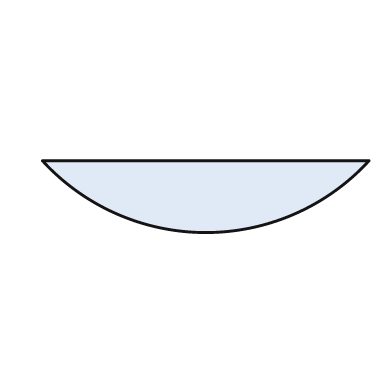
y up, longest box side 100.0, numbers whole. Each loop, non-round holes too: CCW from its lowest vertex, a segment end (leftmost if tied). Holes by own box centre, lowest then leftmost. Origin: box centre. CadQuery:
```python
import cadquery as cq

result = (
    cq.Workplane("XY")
    .moveTo(-50.0, 11.0)
    .threePointArc((0.0, -11.0), (50.0, 11.0))
    .close()
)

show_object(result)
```